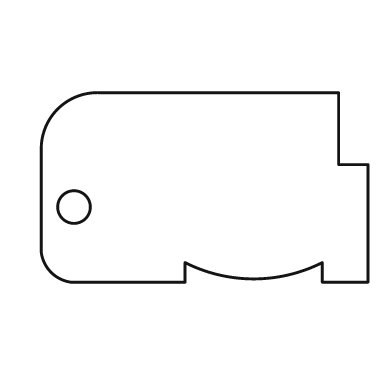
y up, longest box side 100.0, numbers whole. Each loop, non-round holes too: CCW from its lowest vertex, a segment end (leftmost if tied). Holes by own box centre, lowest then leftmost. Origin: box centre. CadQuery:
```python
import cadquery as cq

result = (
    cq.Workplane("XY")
    .moveTo(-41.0, -29.0)
    .lineTo(-6.0, -29.0)
    .lineTo(-6.0, -23.0)
    .threePointArc((15.0, -28.0), (36.0, -23.0))
    .lineTo(36.0, -29.0)
    .lineTo(50.0, -29.0)
    .lineTo(50.0, 7.0)
    .lineTo(41.0, 7.0)
    .lineTo(41.0, 29.0)
    .lineTo(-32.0, 29.0)
    .threePointArc((-45.0, 24.0), (-50.0, 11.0))
    .lineTo(-50.0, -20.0)
    .threePointArc((-47.0, -26.0), (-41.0, -29.0))
    .close()
    .moveTo(-40.0, -6.0)
    .circle(5.0)
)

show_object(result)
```